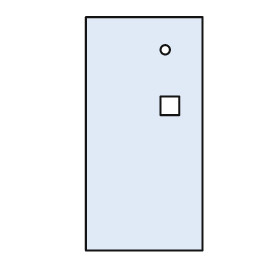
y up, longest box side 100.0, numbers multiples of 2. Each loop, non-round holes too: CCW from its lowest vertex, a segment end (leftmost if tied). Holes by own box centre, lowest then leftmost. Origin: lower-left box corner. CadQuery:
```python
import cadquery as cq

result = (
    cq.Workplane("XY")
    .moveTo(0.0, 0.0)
    .lineTo(50.0, 0.0)
    .lineTo(50.0, 100.0)
    .lineTo(0.0, 100.0)
    .close()
    .moveTo(32.0, 58.0)
    .lineTo(40.0, 58.0)
    .lineTo(40.0, 66.0)
    .lineTo(32.0, 66.0)
    .close()
    .moveTo(34.0, 86.0)
    .circle(2.0)
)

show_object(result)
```